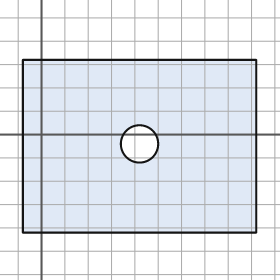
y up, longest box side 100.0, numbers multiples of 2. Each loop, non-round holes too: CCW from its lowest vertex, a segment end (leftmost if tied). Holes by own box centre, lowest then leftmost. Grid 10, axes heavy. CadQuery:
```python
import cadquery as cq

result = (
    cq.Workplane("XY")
    .moveTo(-8.0, -42.0)
    .lineTo(92.0, -42.0)
    .lineTo(92.0, 32.0)
    .lineTo(-8.0, 32.0)
    .close()
    .moveTo(42.0, -4.0)
    .circle(8.0)
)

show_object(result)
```